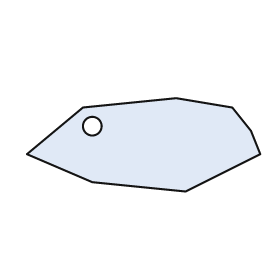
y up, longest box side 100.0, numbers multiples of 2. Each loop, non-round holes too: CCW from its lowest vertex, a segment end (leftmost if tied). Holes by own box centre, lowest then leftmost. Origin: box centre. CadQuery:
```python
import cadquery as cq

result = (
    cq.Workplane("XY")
    .moveTo(18.0, -20.0)
    .lineTo(50.0, -4.0)
    .lineTo(46.0, 6.0)
    .lineTo(38.0, 16.0)
    .lineTo(14.0, 20.0)
    .lineTo(-26.0, 16.0)
    .lineTo(-50.0, -4.0)
    .lineTo(-22.0, -16.0)
    .close()
    .moveTo(-22.0, 8.0)
    .circle(4.0)
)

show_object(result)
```